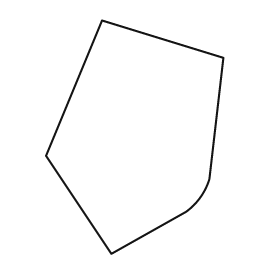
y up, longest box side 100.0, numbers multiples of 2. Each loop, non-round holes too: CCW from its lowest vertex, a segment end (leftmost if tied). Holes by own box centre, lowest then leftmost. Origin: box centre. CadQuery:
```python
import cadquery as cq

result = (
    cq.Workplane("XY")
    .moveTo(-10.0, -50.0)
    .lineTo(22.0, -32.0)
    .threePointArc((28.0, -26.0), (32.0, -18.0))
    .lineTo(38.0, 34.0)
    .lineTo(-14.0, 50.0)
    .lineTo(-38.0, -8.0)
    .close()
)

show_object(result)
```